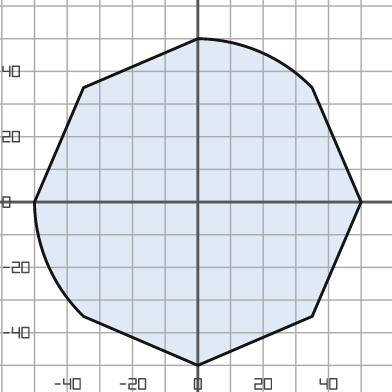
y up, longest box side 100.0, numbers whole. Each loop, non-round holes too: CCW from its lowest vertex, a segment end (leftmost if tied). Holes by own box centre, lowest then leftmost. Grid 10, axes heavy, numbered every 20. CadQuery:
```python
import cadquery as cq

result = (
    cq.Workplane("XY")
    .moveTo(0.0, -50.0)
    .lineTo(35.0, -35.0)
    .lineTo(50.0, 0.0)
    .lineTo(35.0, 35.0)
    .threePointArc((19.0, 46.0), (0.0, 50.0))
    .lineTo(-35.0, 35.0)
    .lineTo(-50.0, 0.0)
    .threePointArc((-46.0, -19.0), (-35.0, -35.0))
    .close()
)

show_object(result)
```